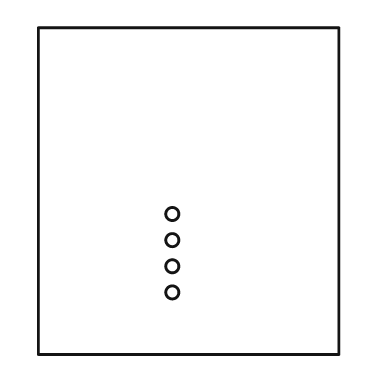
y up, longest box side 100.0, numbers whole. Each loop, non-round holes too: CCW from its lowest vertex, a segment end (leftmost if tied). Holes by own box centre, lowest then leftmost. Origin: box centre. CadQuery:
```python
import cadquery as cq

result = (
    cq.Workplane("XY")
    .moveTo(-46.0, -50.0)
    .lineTo(46.0, -50.0)
    .lineTo(46.0, 50.0)
    .lineTo(-46.0, 50.0)
    .close()
    .moveTo(-5.0, -31.0)
    .circle(2.0)
    .moveTo(-5.0, -23.0)
    .circle(2.0)
    .moveTo(-5.0, -15.0)
    .circle(2.0)
    .moveTo(-5.0, -7.0)
    .circle(2.0)
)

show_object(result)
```